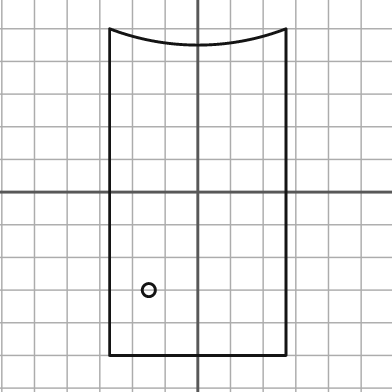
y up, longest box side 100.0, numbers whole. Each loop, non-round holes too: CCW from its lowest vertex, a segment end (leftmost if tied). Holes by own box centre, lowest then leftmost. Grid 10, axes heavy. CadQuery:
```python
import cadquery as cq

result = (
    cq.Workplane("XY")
    .moveTo(-27.0, -50.0)
    .lineTo(27.0, -50.0)
    .lineTo(27.0, 50.0)
    .threePointArc((0.0, 45.0), (-27.0, 50.0))
    .close()
    .moveTo(-15.0, -30.0)
    .circle(2.0)
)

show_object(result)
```